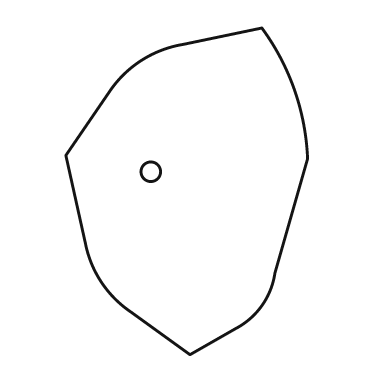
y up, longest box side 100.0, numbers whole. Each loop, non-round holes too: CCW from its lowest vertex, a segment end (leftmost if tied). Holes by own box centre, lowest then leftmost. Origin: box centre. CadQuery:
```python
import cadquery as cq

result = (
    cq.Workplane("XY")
    .moveTo(1.0, -50.0)
    .lineTo(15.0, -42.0)
    .threePointArc((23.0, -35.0), (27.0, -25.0))
    .lineTo(37.0, 10.0)
    .threePointArc((33.0, 31.0), (23.0, 50.0))
    .lineTo(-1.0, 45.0)
    .threePointArc((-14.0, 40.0), (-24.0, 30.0))
    .lineTo(-37.0, 11.0)
    .lineTo(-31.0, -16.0)
    .threePointArc((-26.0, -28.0), (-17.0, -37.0))
    .close()
    .moveTo(-11.0, 6.0)
    .circle(3.0)
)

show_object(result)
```